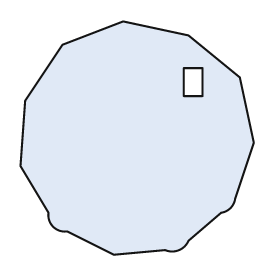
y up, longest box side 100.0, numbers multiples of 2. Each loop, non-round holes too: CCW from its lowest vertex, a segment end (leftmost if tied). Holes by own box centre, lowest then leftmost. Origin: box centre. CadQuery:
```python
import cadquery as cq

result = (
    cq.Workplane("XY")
    .moveTo(-10.0, -50.0)
    .lineTo(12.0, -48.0)
    .threePointArc((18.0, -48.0), (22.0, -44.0))
    .lineTo(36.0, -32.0)
    .threePointArc((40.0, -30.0), (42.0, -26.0))
    .lineTo(50.0, -2.0)
    .lineTo(44.0, 26.0)
    .lineTo(22.0, 44.0)
    .lineTo(-6.0, 50.0)
    .lineTo(-32.0, 40.0)
    .lineTo(-48.0, 16.0)
    .lineTo(-50.0, -12.0)
    .lineTo(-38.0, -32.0)
    .threePointArc((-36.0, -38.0), (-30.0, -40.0))
    .close()
    .moveTo(20.0, 18.0)
    .lineTo(28.0, 18.0)
    .lineTo(28.0, 30.0)
    .lineTo(20.0, 30.0)
    .close()
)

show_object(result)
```